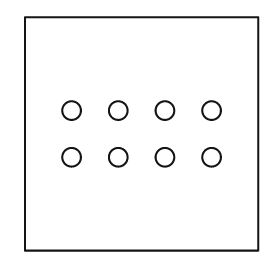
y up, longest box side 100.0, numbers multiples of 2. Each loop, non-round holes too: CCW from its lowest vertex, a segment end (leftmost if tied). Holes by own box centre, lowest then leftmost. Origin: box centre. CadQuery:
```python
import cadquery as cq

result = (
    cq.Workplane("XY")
    .moveTo(-50.0, -50.0)
    .lineTo(50.0, -50.0)
    .lineTo(50.0, 50.0)
    .lineTo(-50.0, 50.0)
    .close()
    .moveTo(-30.0, -10.0)
    .circle(4.0)
    .moveTo(-10.0, -10.0)
    .circle(4.0)
    .moveTo(10.0, -10.0)
    .circle(4.0)
    .moveTo(30.0, -10.0)
    .circle(4.0)
    .moveTo(-30.0, 10.0)
    .circle(4.0)
    .moveTo(-10.0, 10.0)
    .circle(4.0)
    .moveTo(10.0, 10.0)
    .circle(4.0)
    .moveTo(30.0, 10.0)
    .circle(4.0)
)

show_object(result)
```